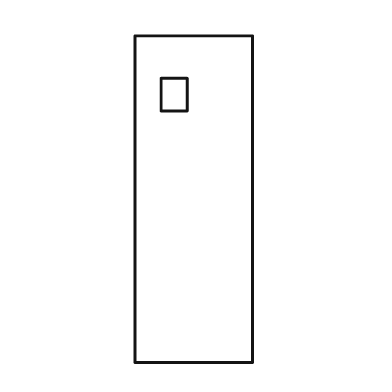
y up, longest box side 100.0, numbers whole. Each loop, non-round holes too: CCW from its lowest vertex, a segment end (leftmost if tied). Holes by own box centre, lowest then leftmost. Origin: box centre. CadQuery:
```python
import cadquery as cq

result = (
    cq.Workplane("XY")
    .moveTo(-18.0, -50.0)
    .lineTo(18.0, -50.0)
    .lineTo(18.0, 50.0)
    .lineTo(-18.0, 50.0)
    .close()
    .moveTo(-10.0, 27.0)
    .lineTo(-2.0, 27.0)
    .lineTo(-2.0, 37.0)
    .lineTo(-10.0, 37.0)
    .close()
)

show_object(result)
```